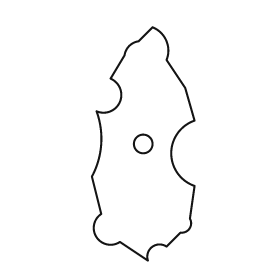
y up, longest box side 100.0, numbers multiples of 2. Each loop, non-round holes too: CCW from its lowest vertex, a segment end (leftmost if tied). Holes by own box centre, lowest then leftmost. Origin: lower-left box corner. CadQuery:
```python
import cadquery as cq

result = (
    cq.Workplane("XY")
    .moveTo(24.0, 0.0)
    .threePointArc((26.0, 6.0), (32.0, 6.0))
    .lineTo(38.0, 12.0)
    .threePointArc((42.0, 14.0), (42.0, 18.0))
    .lineTo(44.0, 32.0)
    .threePointArc((34.0, 46.0), (44.0, 60.0))
    .lineTo(40.0, 74.0)
    .lineTo(32.0, 86.0)
    .threePointArc((32.0, 94.0), (26.0, 100.0))
    .lineTo(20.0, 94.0)
    .threePointArc((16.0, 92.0), (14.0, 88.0))
    .lineTo(8.0, 78.0)
    .threePointArc((12.0, 68.0), (2.0, 64.0))
    .threePointArc((4.0, 50.0), (0.0, 36.0))
    .lineTo(4.0, 20.0)
    .threePointArc((2.0, 10.0), (12.0, 8.0))
    .close()
    .moveTo(22.0, 50.0)
    .circle(4.0)
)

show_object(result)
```